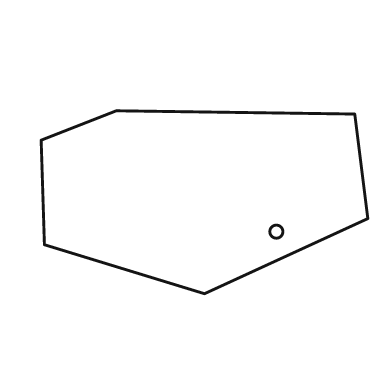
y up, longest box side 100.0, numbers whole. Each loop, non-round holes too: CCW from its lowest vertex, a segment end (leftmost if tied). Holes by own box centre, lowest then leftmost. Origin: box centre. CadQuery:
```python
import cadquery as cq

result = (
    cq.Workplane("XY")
    .moveTo(0.0, -28.0)
    .lineTo(50.0, -5.0)
    .lineTo(46.0, 27.0)
    .lineTo(-27.0, 28.0)
    .lineTo(-50.0, 19.0)
    .lineTo(-49.0, -13.0)
    .close()
    .moveTo(22.0, -9.0)
    .circle(2.0)
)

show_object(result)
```